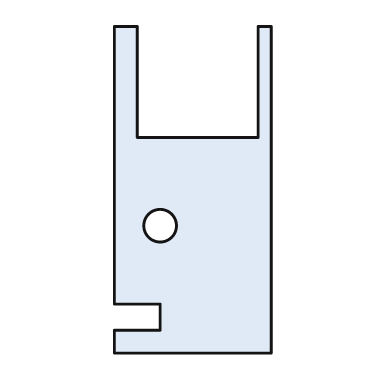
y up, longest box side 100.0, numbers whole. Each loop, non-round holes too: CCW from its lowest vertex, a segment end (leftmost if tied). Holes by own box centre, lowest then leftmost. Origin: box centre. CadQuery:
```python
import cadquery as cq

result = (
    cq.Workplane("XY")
    .moveTo(-24.0, -50.0)
    .lineTo(24.0, -50.0)
    .lineTo(24.0, 50.0)
    .lineTo(20.0, 50.0)
    .lineTo(20.0, 16.0)
    .lineTo(-17.0, 16.0)
    .lineTo(-17.0, 50.0)
    .lineTo(-24.0, 50.0)
    .lineTo(-24.0, -35.0)
    .lineTo(-10.0, -35.0)
    .lineTo(-10.0, -43.0)
    .lineTo(-24.0, -43.0)
    .close()
    .moveTo(-10.0, -11.0)
    .circle(5.0)
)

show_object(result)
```